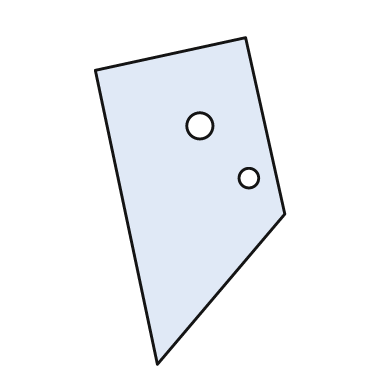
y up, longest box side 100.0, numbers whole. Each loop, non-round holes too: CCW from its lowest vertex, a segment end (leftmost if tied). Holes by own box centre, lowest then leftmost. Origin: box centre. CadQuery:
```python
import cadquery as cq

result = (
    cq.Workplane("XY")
    .moveTo(-10.0, -50.0)
    .lineTo(29.0, -4.0)
    .lineTo(17.0, 50.0)
    .lineTo(-29.0, 40.0)
    .close()
    .moveTo(18.0, 7.0)
    .circle(3.0)
    .moveTo(3.0, 23.0)
    .circle(4.0)
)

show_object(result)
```